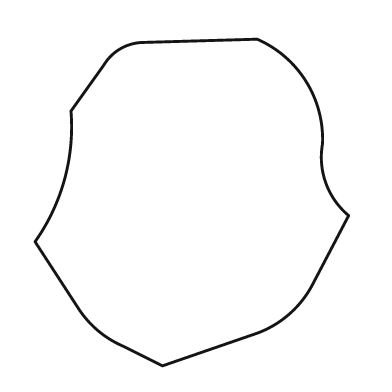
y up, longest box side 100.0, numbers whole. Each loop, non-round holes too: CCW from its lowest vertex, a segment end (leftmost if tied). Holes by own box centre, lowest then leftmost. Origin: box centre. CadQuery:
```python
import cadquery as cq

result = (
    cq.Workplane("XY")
    .moveTo(-9.0, -50.0)
    .lineTo(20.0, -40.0)
    .threePointArc((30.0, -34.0), (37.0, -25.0))
    .lineTo(48.0, -4.0)
    .threePointArc((41.0, 6.0), (40.0, 18.0))
    .threePointArc((35.0, 37.0), (20.0, 50.0))
    .lineTo(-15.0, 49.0)
    .threePointArc((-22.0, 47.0), (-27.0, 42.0))
    .lineTo(-37.0, 28.0)
    .threePointArc((-39.0, 7.0), (-48.0, -12.0))
    .lineTo(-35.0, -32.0)
    .threePointArc((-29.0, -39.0), (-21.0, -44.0))
    .close()
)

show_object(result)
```